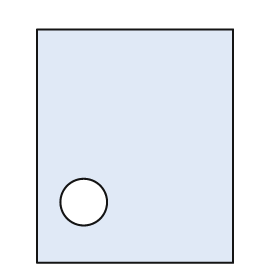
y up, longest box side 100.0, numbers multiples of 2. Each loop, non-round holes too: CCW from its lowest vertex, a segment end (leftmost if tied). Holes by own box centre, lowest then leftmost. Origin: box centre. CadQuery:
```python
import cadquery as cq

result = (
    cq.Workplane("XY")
    .moveTo(-42.0, -50.0)
    .lineTo(42.0, -50.0)
    .lineTo(42.0, 50.0)
    .lineTo(-42.0, 50.0)
    .close()
    .moveTo(-22.0, -24.0)
    .circle(10.0)
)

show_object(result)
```